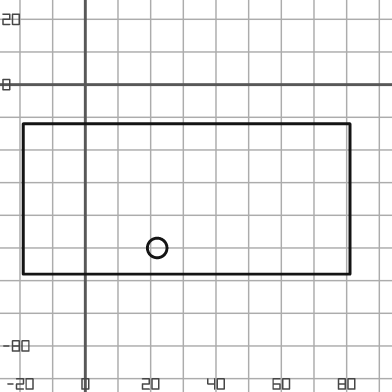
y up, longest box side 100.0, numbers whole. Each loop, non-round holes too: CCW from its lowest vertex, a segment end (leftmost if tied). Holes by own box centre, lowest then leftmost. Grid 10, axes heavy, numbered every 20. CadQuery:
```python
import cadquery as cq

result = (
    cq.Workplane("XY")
    .moveTo(-19.0, -58.0)
    .lineTo(81.0, -58.0)
    .lineTo(81.0, -12.0)
    .lineTo(-19.0, -12.0)
    .close()
    .moveTo(22.0, -50.0)
    .circle(3.0)
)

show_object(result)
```